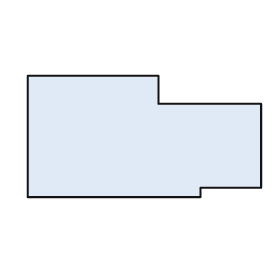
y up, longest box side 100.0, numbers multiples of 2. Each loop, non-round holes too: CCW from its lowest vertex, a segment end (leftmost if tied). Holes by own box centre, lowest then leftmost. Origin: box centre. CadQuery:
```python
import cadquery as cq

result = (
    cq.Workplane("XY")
    .moveTo(-50.0, -26.0)
    .lineTo(24.0, -26.0)
    .lineTo(24.0, -22.0)
    .lineTo(50.0, -22.0)
    .lineTo(50.0, 14.0)
    .lineTo(6.0, 14.0)
    .lineTo(6.0, 26.0)
    .lineTo(-50.0, 26.0)
    .close()
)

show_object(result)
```